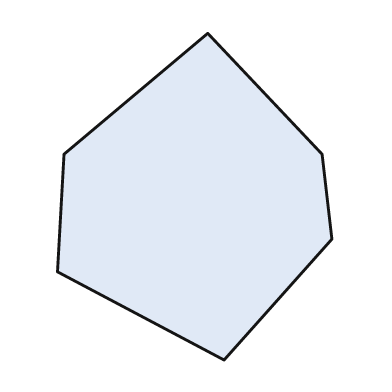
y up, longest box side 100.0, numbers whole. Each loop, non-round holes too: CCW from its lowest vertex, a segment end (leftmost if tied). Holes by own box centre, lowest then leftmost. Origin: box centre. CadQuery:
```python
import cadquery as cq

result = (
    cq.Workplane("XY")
    .moveTo(9.0, -50.0)
    .lineTo(42.0, -13.0)
    .lineTo(39.0, 13.0)
    .lineTo(4.0, 50.0)
    .lineTo(-40.0, 13.0)
    .lineTo(-42.0, -23.0)
    .close()
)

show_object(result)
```